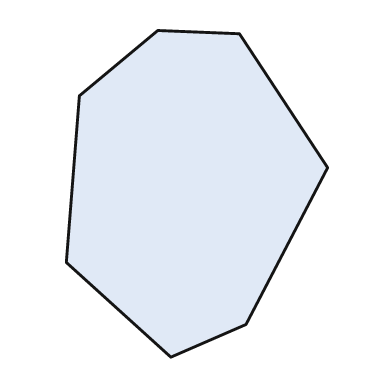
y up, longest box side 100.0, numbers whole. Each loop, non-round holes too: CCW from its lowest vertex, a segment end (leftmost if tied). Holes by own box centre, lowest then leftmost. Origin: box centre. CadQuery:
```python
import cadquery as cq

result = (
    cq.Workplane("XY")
    .moveTo(-8.0, -50.0)
    .lineTo(15.0, -40.0)
    .lineTo(40.0, 8.0)
    .lineTo(13.0, 49.0)
    .lineTo(-12.0, 50.0)
    .lineTo(-36.0, 30.0)
    .lineTo(-40.0, -21.0)
    .close()
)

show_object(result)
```